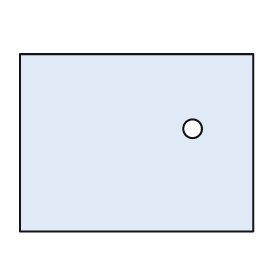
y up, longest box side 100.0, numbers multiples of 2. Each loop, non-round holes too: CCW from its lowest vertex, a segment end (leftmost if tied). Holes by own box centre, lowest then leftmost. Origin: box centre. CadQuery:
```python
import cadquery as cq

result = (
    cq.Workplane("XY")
    .moveTo(-50.0, -38.0)
    .lineTo(50.0, -38.0)
    .lineTo(50.0, 38.0)
    .lineTo(-50.0, 38.0)
    .close()
    .moveTo(24.0, 6.0)
    .circle(4.0)
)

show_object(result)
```